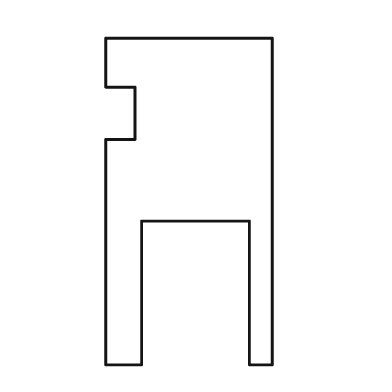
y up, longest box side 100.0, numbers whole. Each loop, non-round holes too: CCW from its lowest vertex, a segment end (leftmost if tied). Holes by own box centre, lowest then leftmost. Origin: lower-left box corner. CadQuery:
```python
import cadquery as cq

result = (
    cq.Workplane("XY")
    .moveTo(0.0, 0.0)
    .lineTo(11.0, 0.0)
    .lineTo(11.0, 44.0)
    .lineTo(44.0, 44.0)
    .lineTo(44.0, 0.0)
    .lineTo(51.0, 0.0)
    .lineTo(51.0, 100.0)
    .lineTo(0.0, 100.0)
    .lineTo(0.0, 85.0)
    .lineTo(9.0, 85.0)
    .lineTo(9.0, 69.0)
    .lineTo(0.0, 69.0)
    .close()
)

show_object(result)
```